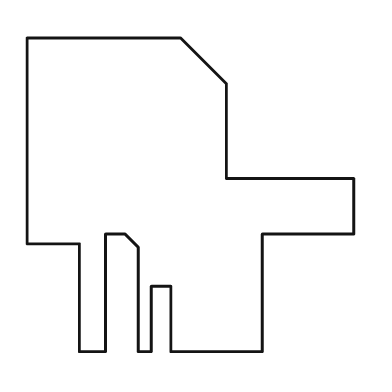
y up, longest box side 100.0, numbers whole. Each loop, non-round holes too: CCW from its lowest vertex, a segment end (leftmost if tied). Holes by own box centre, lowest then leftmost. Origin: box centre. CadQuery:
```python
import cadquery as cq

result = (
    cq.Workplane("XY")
    .moveTo(-34.0, -48.0)
    .lineTo(-26.0, -48.0)
    .lineTo(-26.0, -12.0)
    .lineTo(-20.0, -12.0)
    .lineTo(-16.0, -16.0)
    .lineTo(-16.0, -48.0)
    .lineTo(-12.0, -48.0)
    .lineTo(-12.0, -28.0)
    .lineTo(-6.0, -28.0)
    .lineTo(-6.0, -48.0)
    .lineTo(22.0, -48.0)
    .lineTo(22.0, -12.0)
    .lineTo(50.0, -12.0)
    .lineTo(50.0, 5.0)
    .lineTo(11.0, 5.0)
    .lineTo(11.0, 34.0)
    .lineTo(-3.0, 48.0)
    .lineTo(-50.0, 48.0)
    .lineTo(-50.0, -15.0)
    .lineTo(-34.0, -15.0)
    .close()
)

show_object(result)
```